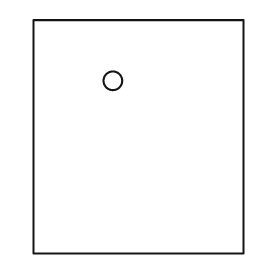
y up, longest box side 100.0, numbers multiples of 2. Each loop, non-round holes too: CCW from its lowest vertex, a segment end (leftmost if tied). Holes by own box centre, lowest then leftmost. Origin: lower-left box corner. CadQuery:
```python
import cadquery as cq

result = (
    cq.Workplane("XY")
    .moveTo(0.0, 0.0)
    .lineTo(90.0, 0.0)
    .lineTo(90.0, 100.0)
    .lineTo(0.0, 100.0)
    .close()
    .moveTo(34.0, 74.0)
    .circle(4.0)
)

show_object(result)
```